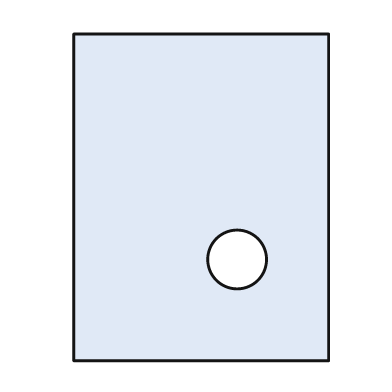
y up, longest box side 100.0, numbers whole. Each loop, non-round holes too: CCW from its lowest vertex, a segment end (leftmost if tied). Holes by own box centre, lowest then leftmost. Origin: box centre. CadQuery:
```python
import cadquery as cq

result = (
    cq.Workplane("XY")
    .moveTo(-39.0, -50.0)
    .lineTo(39.0, -50.0)
    .lineTo(39.0, 50.0)
    .lineTo(-39.0, 50.0)
    .close()
    .moveTo(11.0, -19.0)
    .circle(9.0)
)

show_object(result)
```